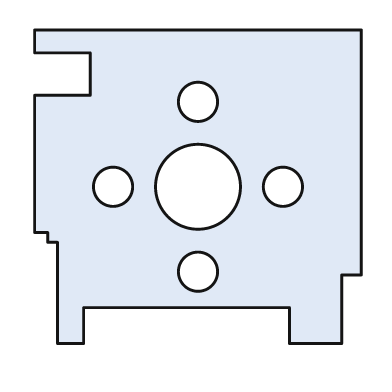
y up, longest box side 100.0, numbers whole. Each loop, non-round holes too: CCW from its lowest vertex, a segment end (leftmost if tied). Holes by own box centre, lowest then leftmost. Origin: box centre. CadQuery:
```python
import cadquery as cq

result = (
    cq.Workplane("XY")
    .moveTo(-43.0, -48.0)
    .lineTo(-35.0, -48.0)
    .lineTo(-35.0, -37.0)
    .lineTo(28.0, -37.0)
    .lineTo(28.0, -48.0)
    .lineTo(44.0, -48.0)
    .lineTo(44.0, -27.0)
    .lineTo(50.0, -27.0)
    .lineTo(50.0, 48.0)
    .lineTo(-50.0, 48.0)
    .lineTo(-50.0, 41.0)
    .lineTo(-33.0, 41.0)
    .lineTo(-33.0, 28.0)
    .lineTo(-50.0, 28.0)
    .lineTo(-50.0, -14.0)
    .lineTo(-46.0, -14.0)
    .lineTo(-46.0, -17.0)
    .lineTo(-43.0, -17.0)
    .close()
    .moveTo(0.0, -26.0)
    .circle(6.0)
    .moveTo(-26.0, 0.0)
    .circle(6.0)
    .moveTo(0.0, 0.0)
    .circle(13.0)
    .moveTo(26.0, 0.0)
    .circle(6.0)
    .moveTo(0.0, 26.0)
    .circle(6.0)
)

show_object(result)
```